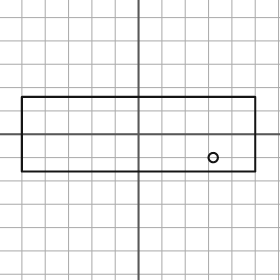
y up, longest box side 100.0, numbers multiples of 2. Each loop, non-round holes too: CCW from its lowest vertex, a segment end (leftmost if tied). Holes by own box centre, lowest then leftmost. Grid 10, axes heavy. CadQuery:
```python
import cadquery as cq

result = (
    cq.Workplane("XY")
    .moveTo(-50.0, -16.0)
    .lineTo(50.0, -16.0)
    .lineTo(50.0, 16.0)
    .lineTo(-50.0, 16.0)
    .close()
    .moveTo(32.0, -10.0)
    .circle(2.0)
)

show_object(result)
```